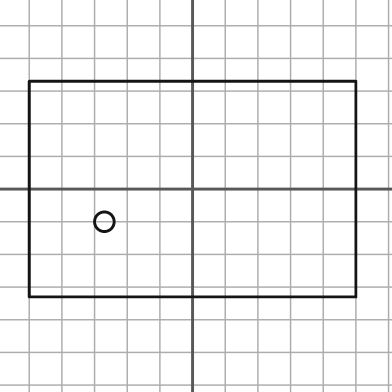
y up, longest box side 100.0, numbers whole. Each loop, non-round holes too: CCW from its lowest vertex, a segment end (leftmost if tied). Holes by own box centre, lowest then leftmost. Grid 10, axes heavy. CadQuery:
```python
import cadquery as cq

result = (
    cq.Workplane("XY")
    .moveTo(-50.0, -33.0)
    .lineTo(50.0, -33.0)
    .lineTo(50.0, 33.0)
    .lineTo(-50.0, 33.0)
    .close()
    .moveTo(-27.0, -10.0)
    .circle(3.0)
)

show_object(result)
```